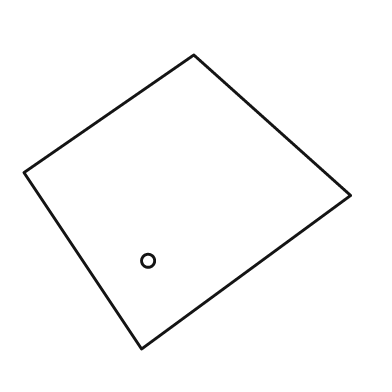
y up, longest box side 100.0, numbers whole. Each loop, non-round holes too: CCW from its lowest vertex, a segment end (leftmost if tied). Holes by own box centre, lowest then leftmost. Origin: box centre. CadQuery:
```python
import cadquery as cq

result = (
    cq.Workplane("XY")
    .moveTo(-14.0, -45.0)
    .lineTo(50.0, 2.0)
    .lineTo(2.0, 45.0)
    .lineTo(-50.0, 9.0)
    .close()
    .moveTo(-12.0, -18.0)
    .circle(2.0)
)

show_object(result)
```